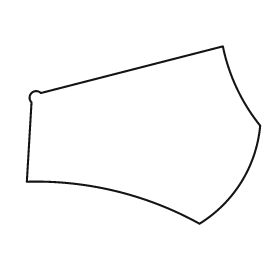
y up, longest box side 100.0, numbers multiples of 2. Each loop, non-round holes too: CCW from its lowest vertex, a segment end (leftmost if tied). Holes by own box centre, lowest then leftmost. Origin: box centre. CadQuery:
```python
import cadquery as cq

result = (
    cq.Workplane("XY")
    .moveTo(24.0, -38.0)
    .threePointArc((42.0, -20.0), (50.0, 4.0))
    .threePointArc((40.0, 20.0), (34.0, 38.0))
    .lineTo(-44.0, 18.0)
    .threePointArc((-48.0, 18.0), (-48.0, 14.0))
    .lineTo(-50.0, -20.0)
    .threePointArc((-12.0, -24.0), (24.0, -38.0))
    .close()
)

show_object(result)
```